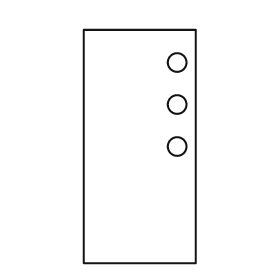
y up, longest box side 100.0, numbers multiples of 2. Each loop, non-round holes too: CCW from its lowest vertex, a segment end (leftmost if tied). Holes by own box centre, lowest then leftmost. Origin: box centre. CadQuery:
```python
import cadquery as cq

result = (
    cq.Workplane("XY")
    .moveTo(-24.0, -50.0)
    .lineTo(24.0, -50.0)
    .lineTo(24.0, 50.0)
    .lineTo(-24.0, 50.0)
    .close()
    .moveTo(16.0, 0.0)
    .circle(4.0)
    .moveTo(16.0, 18.0)
    .circle(4.0)
    .moveTo(16.0, 36.0)
    .circle(4.0)
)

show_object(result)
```